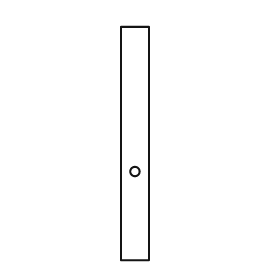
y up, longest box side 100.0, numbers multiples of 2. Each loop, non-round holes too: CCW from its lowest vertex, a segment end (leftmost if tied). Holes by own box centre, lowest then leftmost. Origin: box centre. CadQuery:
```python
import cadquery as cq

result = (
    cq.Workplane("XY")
    .moveTo(-6.0, -50.0)
    .lineTo(6.0, -50.0)
    .lineTo(6.0, 50.0)
    .lineTo(-6.0, 50.0)
    .close()
    .moveTo(0.0, -12.0)
    .circle(2.0)
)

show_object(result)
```